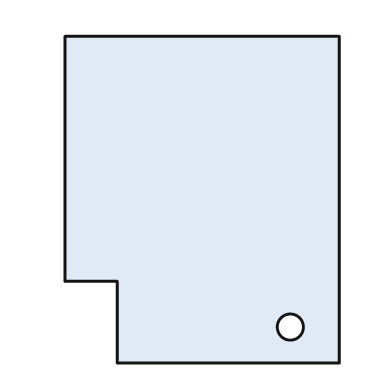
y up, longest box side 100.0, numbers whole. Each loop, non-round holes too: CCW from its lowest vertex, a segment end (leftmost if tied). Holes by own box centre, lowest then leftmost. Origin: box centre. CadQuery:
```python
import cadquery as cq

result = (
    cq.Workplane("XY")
    .moveTo(-26.0, -50.0)
    .lineTo(42.0, -50.0)
    .lineTo(42.0, 50.0)
    .lineTo(-42.0, 50.0)
    .lineTo(-42.0, -25.0)
    .lineTo(-26.0, -25.0)
    .close()
    .moveTo(27.0, -39.0)
    .circle(4.0)
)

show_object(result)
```